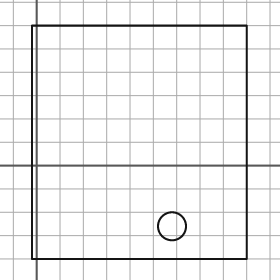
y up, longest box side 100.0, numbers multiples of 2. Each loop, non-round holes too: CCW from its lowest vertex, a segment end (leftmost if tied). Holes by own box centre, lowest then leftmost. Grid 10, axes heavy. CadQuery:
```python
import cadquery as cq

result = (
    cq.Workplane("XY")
    .moveTo(-2.0, -40.0)
    .lineTo(90.0, -40.0)
    .lineTo(90.0, 60.0)
    .lineTo(-2.0, 60.0)
    .close()
    .moveTo(58.0, -26.0)
    .circle(6.0)
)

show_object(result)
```